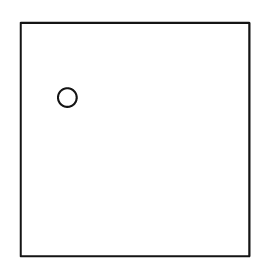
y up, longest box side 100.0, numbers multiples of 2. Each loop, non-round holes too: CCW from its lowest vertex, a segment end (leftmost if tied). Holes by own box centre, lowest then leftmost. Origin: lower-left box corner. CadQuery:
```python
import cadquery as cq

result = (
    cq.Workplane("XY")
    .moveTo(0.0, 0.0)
    .lineTo(98.0, 0.0)
    .lineTo(98.0, 100.0)
    .lineTo(0.0, 100.0)
    .close()
    .moveTo(20.0, 68.0)
    .circle(4.0)
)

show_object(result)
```